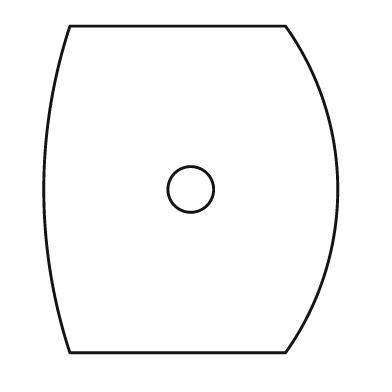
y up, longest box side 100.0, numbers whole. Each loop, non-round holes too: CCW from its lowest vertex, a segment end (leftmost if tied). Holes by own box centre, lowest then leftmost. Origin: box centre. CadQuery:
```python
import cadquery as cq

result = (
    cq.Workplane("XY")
    .moveTo(-37.0, -50.0)
    .lineTo(29.0, -50.0)
    .threePointArc((45.0, 0.0), (29.0, 50.0))
    .lineTo(-37.0, 50.0)
    .threePointArc((-45.0, 0.0), (-37.0, -50.0))
    .close()
    .moveTo(0.0, 0.0)
    .circle(7.0)
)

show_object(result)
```